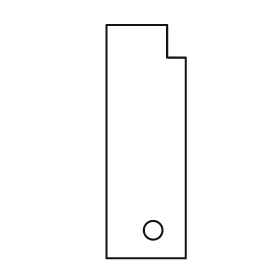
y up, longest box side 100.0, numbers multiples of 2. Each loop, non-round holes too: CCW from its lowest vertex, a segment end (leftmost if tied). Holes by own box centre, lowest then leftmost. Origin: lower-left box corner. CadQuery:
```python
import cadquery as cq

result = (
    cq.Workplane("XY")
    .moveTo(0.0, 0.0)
    .lineTo(34.0, 0.0)
    .lineTo(34.0, 86.0)
    .lineTo(26.0, 86.0)
    .lineTo(26.0, 100.0)
    .lineTo(0.0, 100.0)
    .close()
    .moveTo(20.0, 12.0)
    .circle(4.0)
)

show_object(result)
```